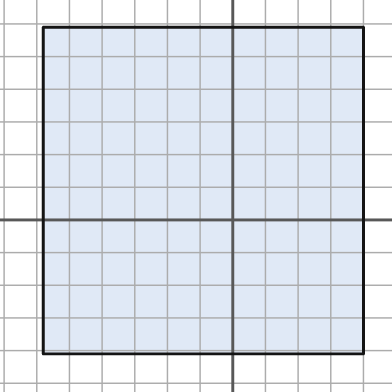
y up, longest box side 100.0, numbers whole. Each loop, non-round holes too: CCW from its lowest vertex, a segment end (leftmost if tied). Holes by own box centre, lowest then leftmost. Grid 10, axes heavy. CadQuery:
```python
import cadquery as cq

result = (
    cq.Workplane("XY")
    .moveTo(-58.0, -41.0)
    .lineTo(40.0, -41.0)
    .lineTo(40.0, 59.0)
    .lineTo(-58.0, 59.0)
    .close()
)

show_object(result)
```